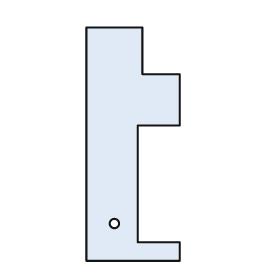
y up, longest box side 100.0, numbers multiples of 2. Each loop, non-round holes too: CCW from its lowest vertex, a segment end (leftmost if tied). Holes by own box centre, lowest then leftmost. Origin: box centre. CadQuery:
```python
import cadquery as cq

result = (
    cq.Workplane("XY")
    .moveTo(-20.0, -50.0)
    .lineTo(20.0, -50.0)
    .lineTo(20.0, -42.0)
    .lineTo(2.0, -42.0)
    .lineTo(2.0, 8.0)
    .lineTo(20.0, 8.0)
    .lineTo(20.0, 30.0)
    .lineTo(4.0, 30.0)
    .lineTo(4.0, 50.0)
    .lineTo(-20.0, 50.0)
    .close()
    .moveTo(-8.0, -34.0)
    .circle(2.0)
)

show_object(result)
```